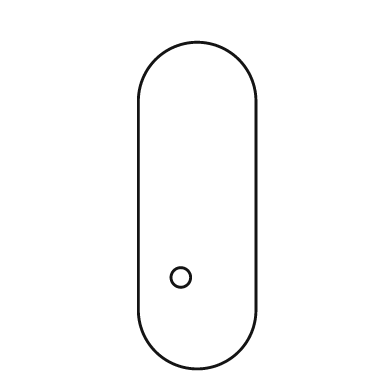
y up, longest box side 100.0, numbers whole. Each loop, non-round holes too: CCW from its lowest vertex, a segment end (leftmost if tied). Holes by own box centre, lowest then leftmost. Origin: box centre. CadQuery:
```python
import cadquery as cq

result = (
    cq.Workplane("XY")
    .moveTo(-18.0, -32.0)
    .threePointArc((0.0, -50.0), (18.0, -32.0))
    .lineTo(18.0, 32.0)
    .threePointArc((0.0, 50.0), (-18.0, 32.0))
    .close()
    .moveTo(-5.0, -22.0)
    .circle(3.0)
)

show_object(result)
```